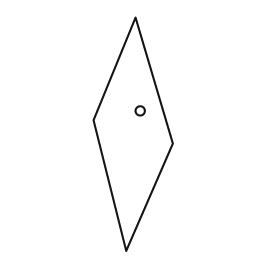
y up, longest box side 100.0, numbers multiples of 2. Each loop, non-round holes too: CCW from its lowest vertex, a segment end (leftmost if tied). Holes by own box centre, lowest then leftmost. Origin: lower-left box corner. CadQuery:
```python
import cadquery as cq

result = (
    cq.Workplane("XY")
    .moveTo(14.0, 0.0)
    .lineTo(34.0, 46.0)
    .lineTo(18.0, 100.0)
    .lineTo(0.0, 56.0)
    .close()
    .moveTo(20.0, 60.0)
    .circle(2.0)
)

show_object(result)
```